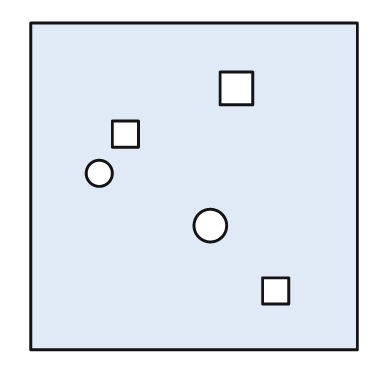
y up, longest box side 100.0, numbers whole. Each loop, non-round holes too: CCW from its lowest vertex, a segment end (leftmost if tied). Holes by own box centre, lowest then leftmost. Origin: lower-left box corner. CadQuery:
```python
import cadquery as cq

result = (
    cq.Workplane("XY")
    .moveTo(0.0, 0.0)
    .lineTo(100.0, 0.0)
    .lineTo(100.0, 100.0)
    .lineTo(0.0, 100.0)
    .close()
    .moveTo(71.0, 14.0)
    .lineTo(79.0, 14.0)
    .lineTo(79.0, 22.0)
    .lineTo(71.0, 22.0)
    .close()
    .moveTo(55.0, 38.0)
    .circle(5.0)
    .moveTo(21.0, 54.0)
    .circle(4.0)
    .moveTo(25.0, 62.0)
    .lineTo(33.0, 62.0)
    .lineTo(33.0, 70.0)
    .lineTo(25.0, 70.0)
    .close()
    .moveTo(58.0, 75.0)
    .lineTo(68.0, 75.0)
    .lineTo(68.0, 85.0)
    .lineTo(58.0, 85.0)
    .close()
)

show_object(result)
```